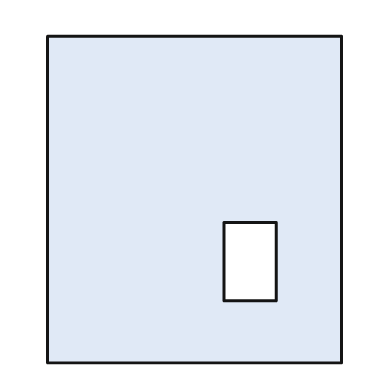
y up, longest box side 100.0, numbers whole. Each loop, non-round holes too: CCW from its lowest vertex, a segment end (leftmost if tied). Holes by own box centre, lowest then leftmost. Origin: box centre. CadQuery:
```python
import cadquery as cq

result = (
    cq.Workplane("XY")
    .moveTo(-45.0, -50.0)
    .lineTo(45.0, -50.0)
    .lineTo(45.0, 50.0)
    .lineTo(-45.0, 50.0)
    .close()
    .moveTo(9.0, -31.0)
    .lineTo(25.0, -31.0)
    .lineTo(25.0, -7.0)
    .lineTo(9.0, -7.0)
    .close()
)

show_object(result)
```